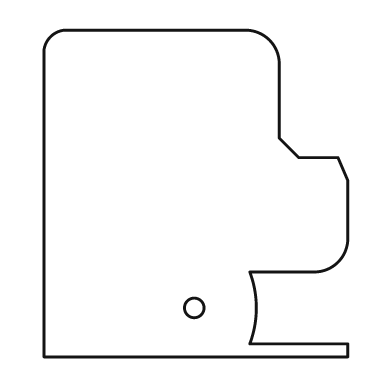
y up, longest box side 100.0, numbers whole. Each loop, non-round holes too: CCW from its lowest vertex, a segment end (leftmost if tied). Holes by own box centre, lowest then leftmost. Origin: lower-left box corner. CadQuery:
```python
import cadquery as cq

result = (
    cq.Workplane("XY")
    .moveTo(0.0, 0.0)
    .lineTo(93.0, 0.0)
    .lineTo(93.0, 4.0)
    .lineTo(63.0, 4.0)
    .threePointArc((65.0, 15.0), (63.0, 26.0))
    .lineTo(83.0, 26.0)
    .threePointArc((90.0, 29.0), (93.0, 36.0))
    .lineTo(93.0, 54.0)
    .lineTo(90.0, 61.0)
    .lineTo(78.0, 61.0)
    .lineTo(72.0, 67.0)
    .lineTo(72.0, 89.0)
    .threePointArc((69.0, 97.0), (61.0, 100.0))
    .lineTo(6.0, 100.0)
    .threePointArc((2.0, 98.0), (0.0, 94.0))
    .close()
    .moveTo(46.0, 15.0)
    .circle(3.0)
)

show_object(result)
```